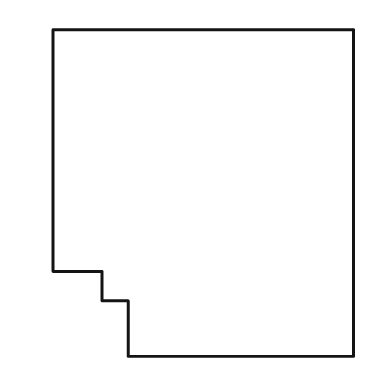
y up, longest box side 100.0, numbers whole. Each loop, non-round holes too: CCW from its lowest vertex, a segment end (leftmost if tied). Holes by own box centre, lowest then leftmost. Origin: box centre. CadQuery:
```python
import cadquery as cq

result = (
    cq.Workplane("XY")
    .moveTo(-23.0, -50.0)
    .lineTo(46.0, -50.0)
    .lineTo(46.0, 50.0)
    .lineTo(-46.0, 50.0)
    .lineTo(-46.0, -24.0)
    .lineTo(-31.0, -24.0)
    .lineTo(-31.0, -33.0)
    .lineTo(-23.0, -33.0)
    .close()
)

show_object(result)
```